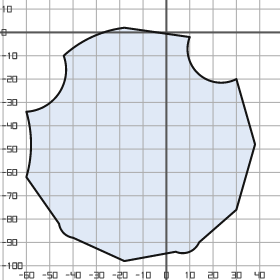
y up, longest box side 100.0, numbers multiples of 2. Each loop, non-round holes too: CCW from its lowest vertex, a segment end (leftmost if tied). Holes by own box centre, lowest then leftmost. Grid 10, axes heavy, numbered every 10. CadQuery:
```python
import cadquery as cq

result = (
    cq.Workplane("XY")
    .moveTo(-18.0, -98.0)
    .lineTo(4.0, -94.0)
    .threePointArc((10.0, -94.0), (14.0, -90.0))
    .lineTo(30.0, -76.0)
    .lineTo(38.0, -48.0)
    .lineTo(30.0, -20.0)
    .threePointArc((14.0, -18.0), (10.0, -2.0))
    .lineTo(-18.0, 2.0)
    .threePointArc((-32.0, -2.0), (-44.0, -10.0))
    .threePointArc((-46.0, -26.0), (-60.0, -34.0))
    .threePointArc((-58.0, -48.0), (-60.0, -62.0))
    .lineTo(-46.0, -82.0)
    .threePointArc((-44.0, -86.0), (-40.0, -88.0))
    .close()
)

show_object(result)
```